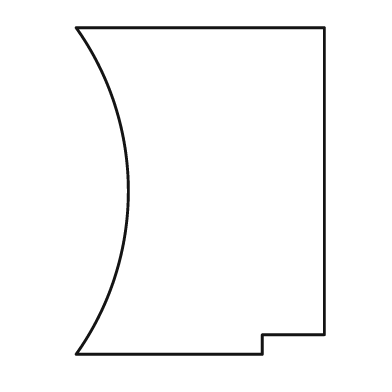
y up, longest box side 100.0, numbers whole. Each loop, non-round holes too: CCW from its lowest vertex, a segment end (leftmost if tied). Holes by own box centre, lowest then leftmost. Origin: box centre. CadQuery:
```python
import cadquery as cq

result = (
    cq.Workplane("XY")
    .moveTo(-38.0, -50.0)
    .lineTo(19.0, -50.0)
    .lineTo(19.0, -44.0)
    .lineTo(38.0, -44.0)
    .lineTo(38.0, 50.0)
    .lineTo(-38.0, 50.0)
    .threePointArc((-22.0, 0.0), (-38.0, -50.0))
    .close()
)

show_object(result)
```